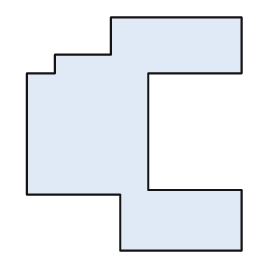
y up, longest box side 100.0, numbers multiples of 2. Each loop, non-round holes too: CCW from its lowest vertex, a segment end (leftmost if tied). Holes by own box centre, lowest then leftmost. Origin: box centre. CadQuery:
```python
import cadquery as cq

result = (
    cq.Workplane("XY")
    .moveTo(-6.0, -50.0)
    .lineTo(46.0, -50.0)
    .lineTo(46.0, -24.0)
    .lineTo(6.0, -24.0)
    .lineTo(6.0, 26.0)
    .lineTo(46.0, 26.0)
    .lineTo(46.0, 50.0)
    .lineTo(-10.0, 50.0)
    .lineTo(-10.0, 34.0)
    .lineTo(-34.0, 34.0)
    .lineTo(-34.0, 26.0)
    .lineTo(-46.0, 26.0)
    .lineTo(-46.0, -26.0)
    .lineTo(-6.0, -26.0)
    .close()
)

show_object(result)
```